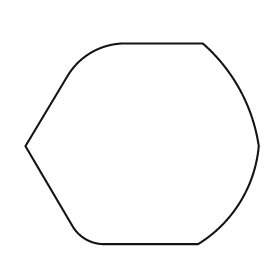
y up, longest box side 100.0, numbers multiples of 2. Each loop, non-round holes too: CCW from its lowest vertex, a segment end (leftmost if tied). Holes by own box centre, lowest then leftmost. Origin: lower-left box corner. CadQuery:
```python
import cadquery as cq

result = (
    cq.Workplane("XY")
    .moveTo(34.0, 0.0)
    .lineTo(74.0, 0.0)
    .threePointArc((92.0, 18.0), (100.0, 42.0))
    .threePointArc((92.0, 66.0), (76.0, 86.0))
    .lineTo(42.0, 86.0)
    .threePointArc((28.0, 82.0), (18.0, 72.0))
    .lineTo(0.0, 42.0)
    .lineTo(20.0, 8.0)
    .threePointArc((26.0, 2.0), (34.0, 0.0))
    .close()
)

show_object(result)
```